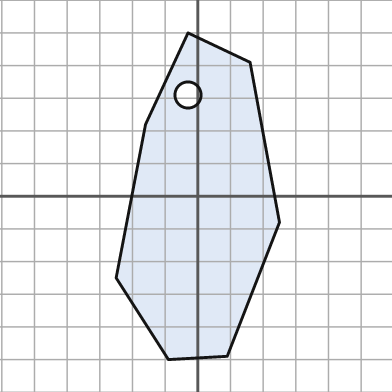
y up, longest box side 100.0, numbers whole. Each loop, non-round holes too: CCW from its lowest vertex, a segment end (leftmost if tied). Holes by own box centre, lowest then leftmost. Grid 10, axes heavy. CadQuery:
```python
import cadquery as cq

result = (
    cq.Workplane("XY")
    .moveTo(-9.0, -50.0)
    .lineTo(9.0, -49.0)
    .lineTo(25.0, -8.0)
    .lineTo(16.0, 41.0)
    .lineTo(-3.0, 50.0)
    .lineTo(-16.0, 22.0)
    .lineTo(-25.0, -25.0)
    .close()
    .moveTo(-3.0, 31.0)
    .circle(4.0)
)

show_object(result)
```